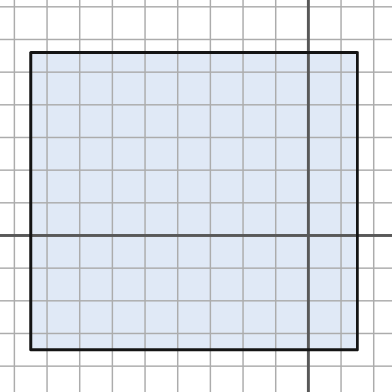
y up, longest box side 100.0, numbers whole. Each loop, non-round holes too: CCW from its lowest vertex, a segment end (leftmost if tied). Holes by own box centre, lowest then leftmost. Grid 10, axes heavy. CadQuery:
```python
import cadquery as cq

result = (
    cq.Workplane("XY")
    .moveTo(-85.0, -35.0)
    .lineTo(15.0, -35.0)
    .lineTo(15.0, 56.0)
    .lineTo(-85.0, 56.0)
    .close()
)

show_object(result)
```